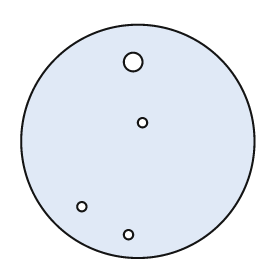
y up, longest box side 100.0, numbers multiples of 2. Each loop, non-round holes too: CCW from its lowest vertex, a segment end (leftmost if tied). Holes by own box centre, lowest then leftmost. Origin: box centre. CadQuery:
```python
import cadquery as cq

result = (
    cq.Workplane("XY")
    .moveTo(0.0, 0.0)
    .circle(50.0)
    .moveTo(-4.0, -40.0)
    .circle(2.0)
    .moveTo(-24.0, -28.0)
    .circle(2.0)
    .moveTo(2.0, 8.0)
    .circle(2.0)
    .moveTo(-2.0, 34.0)
    .circle(4.0)
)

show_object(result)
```